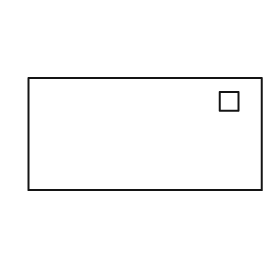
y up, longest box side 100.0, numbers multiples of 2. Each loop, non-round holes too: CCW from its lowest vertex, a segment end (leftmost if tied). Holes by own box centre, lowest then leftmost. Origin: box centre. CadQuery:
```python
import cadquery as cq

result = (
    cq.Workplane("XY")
    .moveTo(-50.0, -24.0)
    .lineTo(50.0, -24.0)
    .lineTo(50.0, 24.0)
    .lineTo(-50.0, 24.0)
    .close()
    .moveTo(32.0, 10.0)
    .lineTo(40.0, 10.0)
    .lineTo(40.0, 18.0)
    .lineTo(32.0, 18.0)
    .close()
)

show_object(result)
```